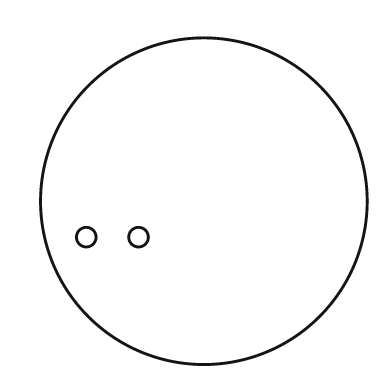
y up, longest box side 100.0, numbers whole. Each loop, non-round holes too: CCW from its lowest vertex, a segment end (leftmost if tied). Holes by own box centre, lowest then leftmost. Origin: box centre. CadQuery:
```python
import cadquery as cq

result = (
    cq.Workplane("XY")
    .moveTo(0.0, 0.0)
    .circle(50.0)
    .moveTo(-36.0, -11.0)
    .circle(3.0)
    .moveTo(-20.0, -11.0)
    .circle(3.0)
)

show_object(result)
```